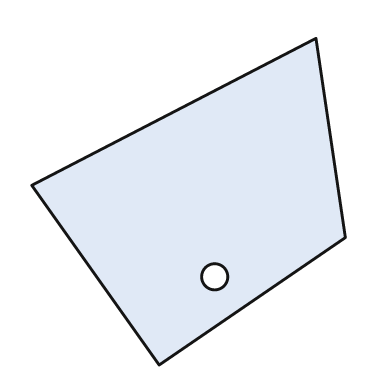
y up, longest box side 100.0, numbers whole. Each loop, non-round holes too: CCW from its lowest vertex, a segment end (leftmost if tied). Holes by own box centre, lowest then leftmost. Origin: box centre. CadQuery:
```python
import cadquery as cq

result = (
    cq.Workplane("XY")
    .moveTo(-9.0, -50.0)
    .lineTo(48.0, -11.0)
    .lineTo(39.0, 50.0)
    .lineTo(-48.0, 5.0)
    .close()
    .moveTo(8.0, -23.0)
    .circle(4.0)
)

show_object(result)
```